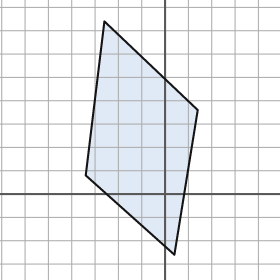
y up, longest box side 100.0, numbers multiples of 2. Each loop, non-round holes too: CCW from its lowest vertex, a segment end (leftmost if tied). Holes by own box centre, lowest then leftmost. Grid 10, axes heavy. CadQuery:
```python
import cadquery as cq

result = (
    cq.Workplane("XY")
    .moveTo(4.0, -26.0)
    .lineTo(14.0, 36.0)
    .lineTo(-26.0, 74.0)
    .lineTo(-34.0, 8.0)
    .close()
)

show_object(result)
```